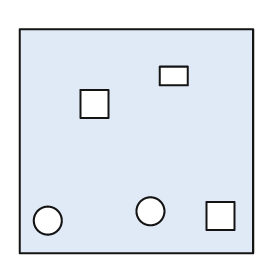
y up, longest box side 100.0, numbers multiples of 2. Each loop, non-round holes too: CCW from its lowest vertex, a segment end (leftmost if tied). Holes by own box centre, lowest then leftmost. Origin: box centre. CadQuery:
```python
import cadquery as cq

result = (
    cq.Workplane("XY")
    .moveTo(-50.0, -48.0)
    .lineTo(50.0, -48.0)
    .lineTo(50.0, 48.0)
    .lineTo(-50.0, 48.0)
    .close()
    .moveTo(-38.0, -34.0)
    .circle(6.0)
    .moveTo(30.0, -38.0)
    .lineTo(42.0, -38.0)
    .lineTo(42.0, -26.0)
    .lineTo(30.0, -26.0)
    .close()
    .moveTo(6.0, -30.0)
    .circle(6.0)
    .moveTo(-24.0, 10.0)
    .lineTo(-12.0, 10.0)
    .lineTo(-12.0, 22.0)
    .lineTo(-24.0, 22.0)
    .close()
    .moveTo(10.0, 24.0)
    .lineTo(22.0, 24.0)
    .lineTo(22.0, 32.0)
    .lineTo(10.0, 32.0)
    .close()
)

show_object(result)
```